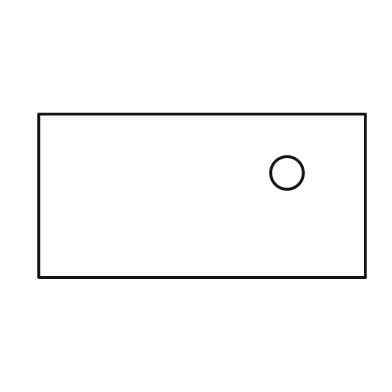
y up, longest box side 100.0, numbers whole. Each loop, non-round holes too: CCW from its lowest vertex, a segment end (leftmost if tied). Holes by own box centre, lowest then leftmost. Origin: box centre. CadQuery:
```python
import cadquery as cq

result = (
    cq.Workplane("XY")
    .moveTo(-50.0, -25.0)
    .lineTo(50.0, -25.0)
    .lineTo(50.0, 25.0)
    .lineTo(-50.0, 25.0)
    .close()
    .moveTo(26.0, 7.0)
    .circle(5.0)
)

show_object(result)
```